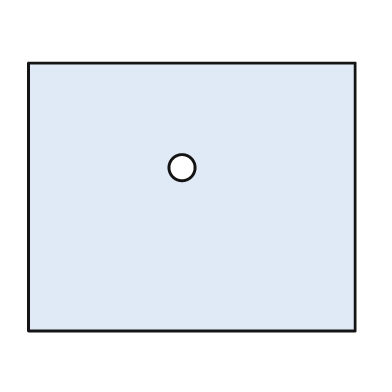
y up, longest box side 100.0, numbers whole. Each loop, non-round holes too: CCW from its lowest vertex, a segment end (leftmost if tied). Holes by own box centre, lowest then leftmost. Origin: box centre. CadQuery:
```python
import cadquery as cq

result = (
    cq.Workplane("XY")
    .moveTo(-50.0, -41.0)
    .lineTo(50.0, -41.0)
    .lineTo(50.0, 41.0)
    .lineTo(-50.0, 41.0)
    .close()
    .moveTo(-3.0, 9.0)
    .circle(4.0)
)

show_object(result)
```